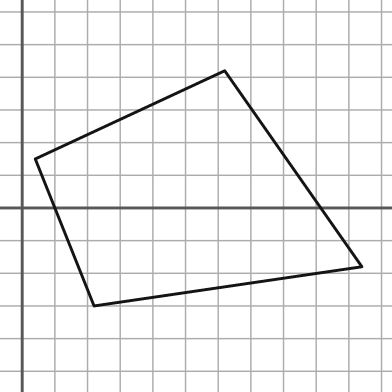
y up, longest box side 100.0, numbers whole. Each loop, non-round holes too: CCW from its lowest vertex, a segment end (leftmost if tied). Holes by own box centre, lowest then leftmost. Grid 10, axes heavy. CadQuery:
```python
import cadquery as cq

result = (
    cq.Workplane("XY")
    .moveTo(22.0, -30.0)
    .lineTo(104.0, -18.0)
    .lineTo(62.0, 42.0)
    .lineTo(4.0, 15.0)
    .close()
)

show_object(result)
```